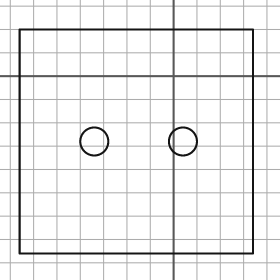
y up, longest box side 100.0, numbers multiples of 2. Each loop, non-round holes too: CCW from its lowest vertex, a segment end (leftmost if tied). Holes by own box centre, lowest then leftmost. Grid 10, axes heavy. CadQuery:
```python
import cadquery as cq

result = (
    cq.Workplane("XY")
    .moveTo(-66.0, -76.0)
    .lineTo(34.0, -76.0)
    .lineTo(34.0, 20.0)
    .lineTo(-66.0, 20.0)
    .close()
    .moveTo(-34.0, -28.0)
    .circle(6.0)
    .moveTo(4.0, -28.0)
    .circle(6.0)
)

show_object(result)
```